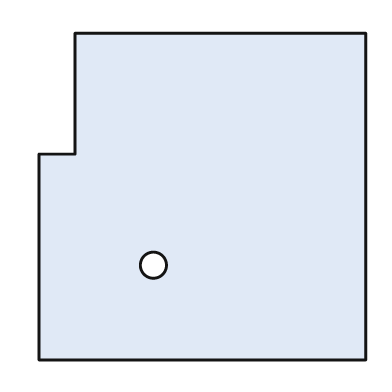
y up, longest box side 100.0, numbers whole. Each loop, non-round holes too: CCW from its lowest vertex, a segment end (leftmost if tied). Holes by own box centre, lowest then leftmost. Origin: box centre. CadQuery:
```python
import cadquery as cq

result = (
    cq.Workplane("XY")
    .moveTo(-50.0, -50.0)
    .lineTo(50.0, -50.0)
    .lineTo(50.0, 50.0)
    .lineTo(-39.0, 50.0)
    .lineTo(-39.0, 13.0)
    .lineTo(-50.0, 13.0)
    .close()
    .moveTo(-15.0, -21.0)
    .circle(4.0)
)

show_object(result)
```